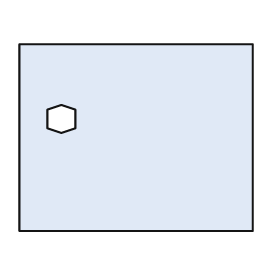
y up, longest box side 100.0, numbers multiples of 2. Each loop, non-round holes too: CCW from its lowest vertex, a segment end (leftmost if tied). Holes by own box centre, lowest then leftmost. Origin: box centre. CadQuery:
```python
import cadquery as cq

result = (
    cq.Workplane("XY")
    .moveTo(-50.0, -40.0)
    .lineTo(50.0, -40.0)
    .lineTo(50.0, 40.0)
    .lineTo(-50.0, 40.0)
    .close()
    .moveTo(-32.0, 2.0)
    .lineTo(-26.0, 4.0)
    .lineTo(-26.0, 12.0)
    .lineTo(-32.0, 14.0)
    .lineTo(-38.0, 12.0)
    .lineTo(-38.0, 4.0)
    .close()
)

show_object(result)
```